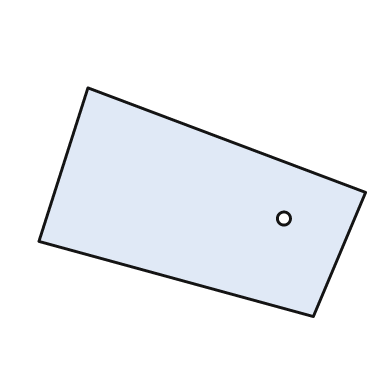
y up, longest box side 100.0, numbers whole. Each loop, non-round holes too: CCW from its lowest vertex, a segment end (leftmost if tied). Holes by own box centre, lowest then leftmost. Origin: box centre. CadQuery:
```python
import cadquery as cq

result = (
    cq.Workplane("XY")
    .moveTo(34.0, -35.0)
    .lineTo(50.0, 3.0)
    .lineTo(-35.0, 35.0)
    .lineTo(-50.0, -12.0)
    .close()
    .moveTo(25.0, -5.0)
    .circle(2.0)
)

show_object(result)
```